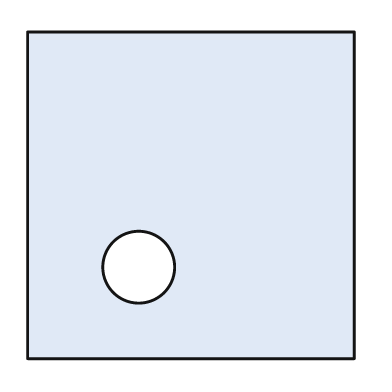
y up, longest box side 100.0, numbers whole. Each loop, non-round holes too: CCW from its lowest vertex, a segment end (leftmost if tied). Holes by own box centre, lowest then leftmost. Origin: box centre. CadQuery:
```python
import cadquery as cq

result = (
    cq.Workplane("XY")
    .moveTo(-50.0, -50.0)
    .lineTo(50.0, -50.0)
    .lineTo(50.0, 50.0)
    .lineTo(-50.0, 50.0)
    .close()
    .moveTo(-16.0, -22.0)
    .circle(11.0)
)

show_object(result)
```